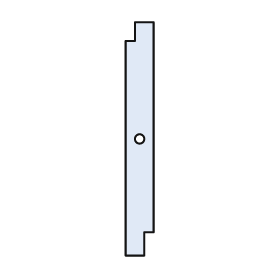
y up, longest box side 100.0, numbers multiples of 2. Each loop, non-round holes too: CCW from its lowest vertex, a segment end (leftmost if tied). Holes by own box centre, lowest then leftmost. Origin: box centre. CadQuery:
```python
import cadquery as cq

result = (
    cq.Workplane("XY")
    .moveTo(-6.0, -50.0)
    .lineTo(2.0, -50.0)
    .lineTo(2.0, -40.0)
    .lineTo(6.0, -40.0)
    .lineTo(6.0, 50.0)
    .lineTo(-2.0, 50.0)
    .lineTo(-2.0, 42.0)
    .lineTo(-6.0, 42.0)
    .close()
    .moveTo(0.0, 0.0)
    .circle(2.0)
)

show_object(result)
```